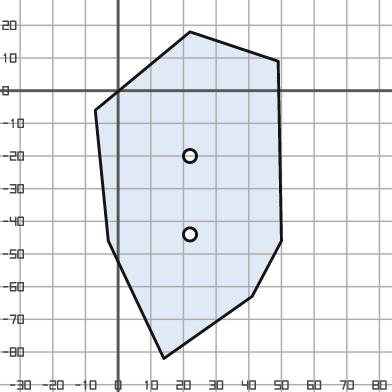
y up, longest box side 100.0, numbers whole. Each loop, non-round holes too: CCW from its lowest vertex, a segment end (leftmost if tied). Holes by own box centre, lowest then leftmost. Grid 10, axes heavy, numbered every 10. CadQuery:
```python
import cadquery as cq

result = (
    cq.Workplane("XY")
    .moveTo(14.0, -82.0)
    .lineTo(41.0, -63.0)
    .lineTo(50.0, -46.0)
    .lineTo(49.0, 9.0)
    .lineTo(22.0, 18.0)
    .lineTo(-7.0, -6.0)
    .lineTo(-3.0, -46.0)
    .close()
    .moveTo(22.0, -44.0)
    .circle(2.0)
    .moveTo(22.0, -20.0)
    .circle(2.0)
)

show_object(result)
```